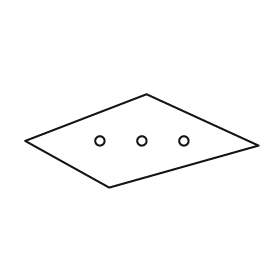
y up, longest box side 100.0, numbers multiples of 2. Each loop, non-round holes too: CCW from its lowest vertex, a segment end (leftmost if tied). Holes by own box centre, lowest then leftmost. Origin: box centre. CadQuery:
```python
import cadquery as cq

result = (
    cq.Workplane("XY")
    .moveTo(-14.0, -20.0)
    .lineTo(50.0, -2.0)
    .lineTo(2.0, 20.0)
    .lineTo(-50.0, 0.0)
    .close()
    .moveTo(-18.0, 0.0)
    .circle(2.0)
    .moveTo(0.0, 0.0)
    .circle(2.0)
    .moveTo(18.0, 0.0)
    .circle(2.0)
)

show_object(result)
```